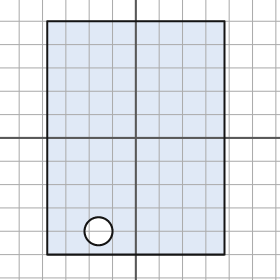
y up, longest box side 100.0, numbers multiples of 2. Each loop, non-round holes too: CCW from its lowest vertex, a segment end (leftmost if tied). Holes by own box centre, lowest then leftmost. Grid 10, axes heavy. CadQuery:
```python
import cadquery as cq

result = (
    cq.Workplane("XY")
    .moveTo(-38.0, -50.0)
    .lineTo(38.0, -50.0)
    .lineTo(38.0, 50.0)
    .lineTo(-38.0, 50.0)
    .close()
    .moveTo(-16.0, -40.0)
    .circle(6.0)
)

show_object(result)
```